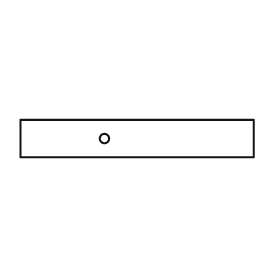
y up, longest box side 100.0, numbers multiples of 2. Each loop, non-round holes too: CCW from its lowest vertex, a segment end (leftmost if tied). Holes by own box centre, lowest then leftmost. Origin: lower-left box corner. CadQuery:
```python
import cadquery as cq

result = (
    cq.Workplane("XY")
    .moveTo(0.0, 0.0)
    .lineTo(100.0, 0.0)
    .lineTo(100.0, 16.0)
    .lineTo(0.0, 16.0)
    .close()
    .moveTo(36.0, 8.0)
    .circle(2.0)
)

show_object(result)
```